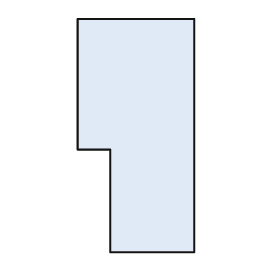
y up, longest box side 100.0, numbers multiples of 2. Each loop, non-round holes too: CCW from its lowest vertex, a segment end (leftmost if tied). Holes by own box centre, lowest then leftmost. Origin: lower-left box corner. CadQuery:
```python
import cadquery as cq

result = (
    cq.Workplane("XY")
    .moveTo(14.0, 0.0)
    .lineTo(50.0, 0.0)
    .lineTo(50.0, 100.0)
    .lineTo(0.0, 100.0)
    .lineTo(0.0, 44.0)
    .lineTo(14.0, 44.0)
    .close()
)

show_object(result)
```